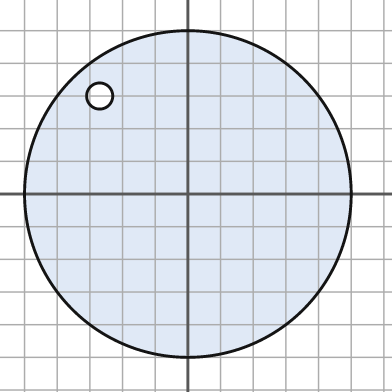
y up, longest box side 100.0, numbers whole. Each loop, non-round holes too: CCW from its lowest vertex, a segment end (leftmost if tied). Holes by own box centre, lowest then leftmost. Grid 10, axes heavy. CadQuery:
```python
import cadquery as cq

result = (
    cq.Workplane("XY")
    .moveTo(0.0, 0.0)
    .circle(50.0)
    .moveTo(-27.0, 30.0)
    .circle(4.0)
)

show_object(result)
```